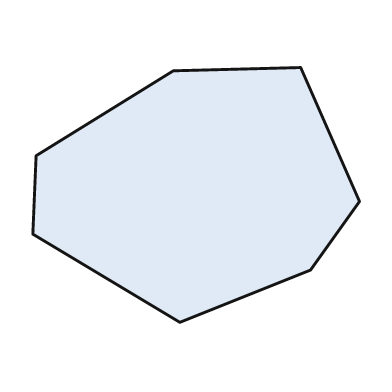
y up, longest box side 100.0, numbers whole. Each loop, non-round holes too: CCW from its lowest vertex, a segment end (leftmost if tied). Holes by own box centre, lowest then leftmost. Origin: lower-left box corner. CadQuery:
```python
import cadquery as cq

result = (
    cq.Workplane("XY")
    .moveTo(45.0, 0.0)
    .lineTo(85.0, 16.0)
    .lineTo(100.0, 37.0)
    .lineTo(82.0, 78.0)
    .lineTo(43.0, 77.0)
    .lineTo(1.0, 51.0)
    .lineTo(0.0, 27.0)
    .close()
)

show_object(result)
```